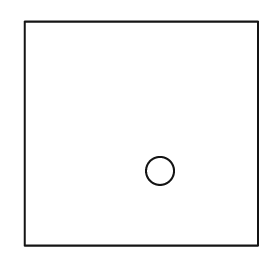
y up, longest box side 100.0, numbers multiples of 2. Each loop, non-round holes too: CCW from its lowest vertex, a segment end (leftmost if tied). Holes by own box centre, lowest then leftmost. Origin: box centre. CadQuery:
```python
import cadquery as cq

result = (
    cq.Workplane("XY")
    .moveTo(-50.0, -48.0)
    .lineTo(50.0, -48.0)
    .lineTo(50.0, 48.0)
    .lineTo(-50.0, 48.0)
    .close()
    .moveTo(8.0, -16.0)
    .circle(6.0)
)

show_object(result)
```